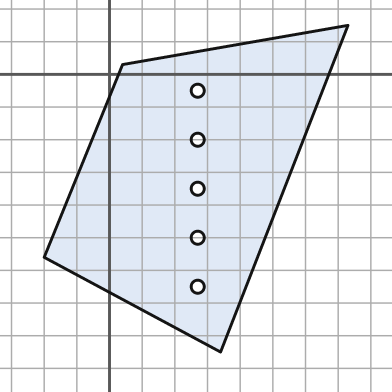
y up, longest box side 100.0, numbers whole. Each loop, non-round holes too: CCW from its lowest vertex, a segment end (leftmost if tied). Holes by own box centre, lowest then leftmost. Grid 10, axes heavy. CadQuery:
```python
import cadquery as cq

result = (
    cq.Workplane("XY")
    .moveTo(34.0, -85.0)
    .lineTo(73.0, 15.0)
    .lineTo(4.0, 3.0)
    .lineTo(-20.0, -56.0)
    .close()
    .moveTo(27.0, -65.0)
    .circle(2.0)
    .moveTo(27.0, -50.0)
    .circle(2.0)
    .moveTo(27.0, -35.0)
    .circle(2.0)
    .moveTo(27.0, -20.0)
    .circle(2.0)
    .moveTo(27.0, -5.0)
    .circle(2.0)
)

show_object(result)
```